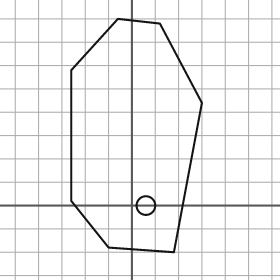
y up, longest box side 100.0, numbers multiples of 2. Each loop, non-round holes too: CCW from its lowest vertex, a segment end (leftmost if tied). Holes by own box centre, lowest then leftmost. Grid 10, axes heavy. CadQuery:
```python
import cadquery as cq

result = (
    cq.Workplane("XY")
    .moveTo(18.0, -20.0)
    .lineTo(30.0, 44.0)
    .lineTo(12.0, 78.0)
    .lineTo(-6.0, 80.0)
    .lineTo(-26.0, 58.0)
    .lineTo(-26.0, 2.0)
    .lineTo(-10.0, -18.0)
    .close()
    .moveTo(6.0, 0.0)
    .circle(4.0)
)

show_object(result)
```